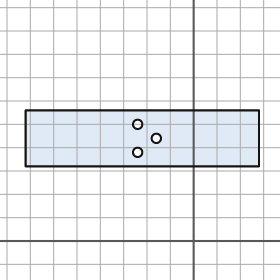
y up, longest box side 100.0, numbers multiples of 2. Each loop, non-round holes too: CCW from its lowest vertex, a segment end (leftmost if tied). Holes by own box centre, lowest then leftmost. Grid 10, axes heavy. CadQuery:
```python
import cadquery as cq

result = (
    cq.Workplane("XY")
    .moveTo(-72.0, 32.0)
    .lineTo(28.0, 32.0)
    .lineTo(28.0, 56.0)
    .lineTo(-72.0, 56.0)
    .close()
    .moveTo(-24.0, 38.0)
    .circle(2.0)
    .moveTo(-16.0, 44.0)
    .circle(2.0)
    .moveTo(-24.0, 50.0)
    .circle(2.0)
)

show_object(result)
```